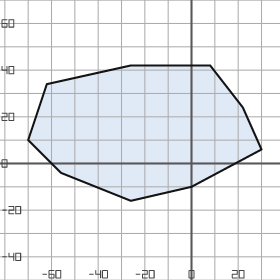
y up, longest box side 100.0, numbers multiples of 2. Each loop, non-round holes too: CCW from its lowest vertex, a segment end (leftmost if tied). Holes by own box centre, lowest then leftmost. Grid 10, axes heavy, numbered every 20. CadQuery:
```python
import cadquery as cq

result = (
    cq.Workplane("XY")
    .moveTo(-26.0, -16.0)
    .lineTo(0.0, -10.0)
    .lineTo(30.0, 6.0)
    .lineTo(22.0, 24.0)
    .lineTo(8.0, 42.0)
    .lineTo(-26.0, 42.0)
    .lineTo(-62.0, 34.0)
    .lineTo(-70.0, 10.0)
    .lineTo(-56.0, -4.0)
    .close()
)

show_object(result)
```